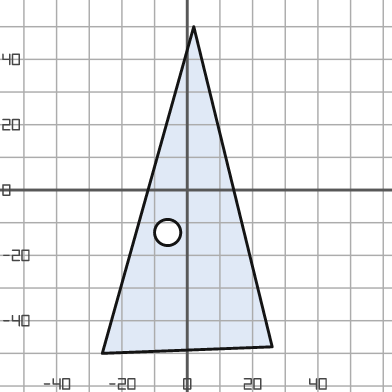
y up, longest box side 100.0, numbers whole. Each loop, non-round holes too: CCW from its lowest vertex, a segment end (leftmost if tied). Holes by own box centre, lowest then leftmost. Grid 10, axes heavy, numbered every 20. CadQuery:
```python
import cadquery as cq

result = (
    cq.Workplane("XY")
    .moveTo(-26.0, -50.0)
    .lineTo(26.0, -48.0)
    .lineTo(2.0, 50.0)
    .close()
    .moveTo(-6.0, -13.0)
    .circle(4.0)
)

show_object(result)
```